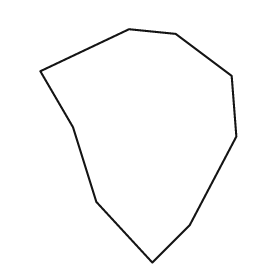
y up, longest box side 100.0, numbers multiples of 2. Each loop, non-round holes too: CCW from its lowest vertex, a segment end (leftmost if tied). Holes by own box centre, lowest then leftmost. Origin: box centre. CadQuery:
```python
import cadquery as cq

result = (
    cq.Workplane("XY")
    .moveTo(6.0, -50.0)
    .lineTo(22.0, -34.0)
    .lineTo(42.0, 4.0)
    .lineTo(40.0, 30.0)
    .lineTo(16.0, 48.0)
    .lineTo(-4.0, 50.0)
    .lineTo(-42.0, 32.0)
    .lineTo(-28.0, 8.0)
    .lineTo(-18.0, -24.0)
    .close()
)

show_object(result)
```